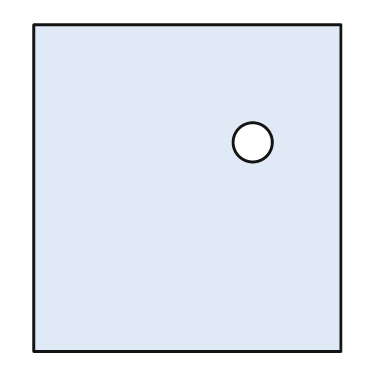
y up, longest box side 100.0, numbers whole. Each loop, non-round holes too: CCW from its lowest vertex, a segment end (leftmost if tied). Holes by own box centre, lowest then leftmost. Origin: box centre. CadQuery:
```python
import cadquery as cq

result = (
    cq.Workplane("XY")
    .moveTo(-47.0, -50.0)
    .lineTo(47.0, -50.0)
    .lineTo(47.0, 50.0)
    .lineTo(-47.0, 50.0)
    .close()
    .moveTo(20.0, 14.0)
    .circle(6.0)
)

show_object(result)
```